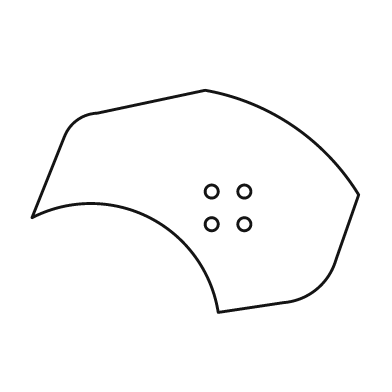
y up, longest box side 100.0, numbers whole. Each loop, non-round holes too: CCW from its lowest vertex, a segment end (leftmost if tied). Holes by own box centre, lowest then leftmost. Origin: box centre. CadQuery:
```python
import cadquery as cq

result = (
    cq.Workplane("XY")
    .moveTo(7.0, -34.0)
    .lineTo(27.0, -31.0)
    .threePointArc((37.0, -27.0), (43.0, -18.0))
    .lineTo(50.0, 2.0)
    .threePointArc((30.0, 23.0), (3.0, 34.0))
    .lineTo(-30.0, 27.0)
    .threePointArc((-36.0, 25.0), (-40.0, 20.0))
    .lineTo(-50.0, -5.0)
    .threePointArc((-14.0, -5.0), (7.0, -34.0))
    .close()
    .moveTo(5.0, -7.0)
    .circle(2.0)
    .moveTo(15.0, -7.0)
    .circle(2.0)
    .moveTo(5.0, 3.0)
    .circle(2.0)
    .moveTo(15.0, 3.0)
    .circle(2.0)
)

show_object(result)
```